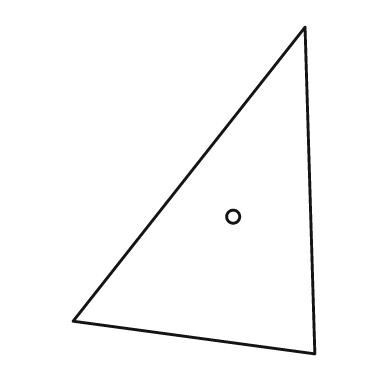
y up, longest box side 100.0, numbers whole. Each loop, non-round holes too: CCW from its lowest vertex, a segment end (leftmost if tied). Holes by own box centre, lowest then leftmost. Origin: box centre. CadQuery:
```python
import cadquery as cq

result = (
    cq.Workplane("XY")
    .moveTo(37.0, -50.0)
    .lineTo(34.0, 50.0)
    .lineTo(-37.0, -40.0)
    .close()
    .moveTo(12.0, -8.0)
    .circle(2.0)
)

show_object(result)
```